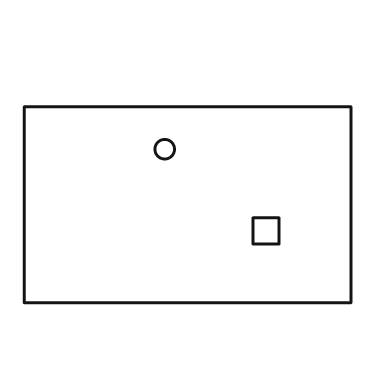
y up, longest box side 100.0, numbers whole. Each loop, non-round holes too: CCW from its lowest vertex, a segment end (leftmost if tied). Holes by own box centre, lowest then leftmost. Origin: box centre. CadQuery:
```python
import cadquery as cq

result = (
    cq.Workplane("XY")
    .moveTo(-50.0, -30.0)
    .lineTo(50.0, -30.0)
    .lineTo(50.0, 30.0)
    .lineTo(-50.0, 30.0)
    .close()
    .moveTo(20.0, -12.0)
    .lineTo(28.0, -12.0)
    .lineTo(28.0, -4.0)
    .lineTo(20.0, -4.0)
    .close()
    .moveTo(-7.0, 17.0)
    .circle(3.0)
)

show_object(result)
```